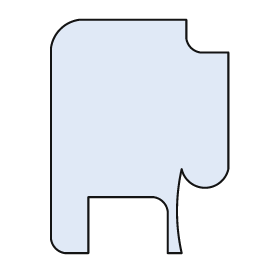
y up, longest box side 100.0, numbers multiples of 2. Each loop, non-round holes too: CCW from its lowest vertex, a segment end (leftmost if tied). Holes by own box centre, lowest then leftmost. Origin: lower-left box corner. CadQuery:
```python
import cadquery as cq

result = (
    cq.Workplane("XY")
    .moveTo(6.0, 0.0)
    .lineTo(16.0, 0.0)
    .lineTo(16.0, 24.0)
    .lineTo(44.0, 24.0)
    .threePointArc((48.0, 22.0), (50.0, 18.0))
    .lineTo(50.0, 0.0)
    .lineTo(56.0, 0.0)
    .threePointArc((54.0, 18.0), (56.0, 36.0))
    .threePointArc((66.0, 28.0), (76.0, 36.0))
    .lineTo(76.0, 86.0)
    .lineTo(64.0, 86.0)
    .threePointArc((60.0, 88.0), (58.0, 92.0))
    .lineTo(58.0, 100.0)
    .lineTo(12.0, 100.0)
    .threePointArc((4.0, 96.0), (0.0, 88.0))
    .lineTo(0.0, 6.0)
    .threePointArc((2.0, 2.0), (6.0, 0.0))
    .close()
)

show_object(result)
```